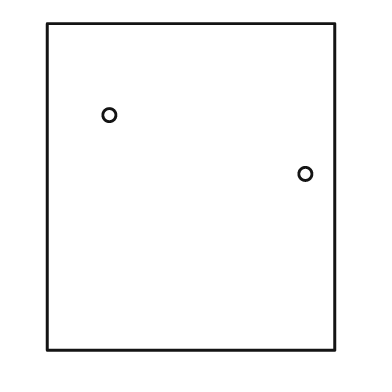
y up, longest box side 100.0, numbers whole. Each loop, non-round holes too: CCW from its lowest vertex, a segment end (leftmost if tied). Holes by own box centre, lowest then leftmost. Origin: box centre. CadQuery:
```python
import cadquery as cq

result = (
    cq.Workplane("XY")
    .moveTo(-44.0, -50.0)
    .lineTo(44.0, -50.0)
    .lineTo(44.0, 50.0)
    .lineTo(-44.0, 50.0)
    .close()
    .moveTo(35.0, 4.0)
    .circle(2.0)
    .moveTo(-25.0, 22.0)
    .circle(2.0)
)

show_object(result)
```